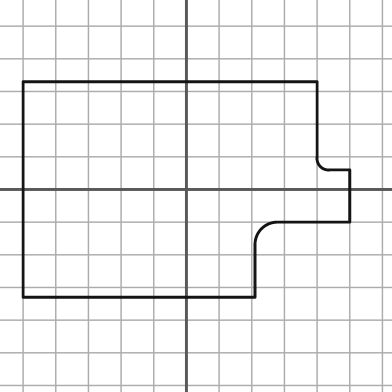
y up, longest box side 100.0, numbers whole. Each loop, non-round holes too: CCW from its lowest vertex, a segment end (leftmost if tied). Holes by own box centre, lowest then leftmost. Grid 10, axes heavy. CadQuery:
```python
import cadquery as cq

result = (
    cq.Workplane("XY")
    .moveTo(-50.0, -33.0)
    .lineTo(21.0, -33.0)
    .lineTo(21.0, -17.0)
    .threePointArc((23.0, -12.0), (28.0, -10.0))
    .lineTo(50.0, -10.0)
    .lineTo(50.0, 6.0)
    .lineTo(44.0, 6.0)
    .threePointArc((41.0, 7.0), (40.0, 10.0))
    .lineTo(40.0, 33.0)
    .lineTo(-50.0, 33.0)
    .close()
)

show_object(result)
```